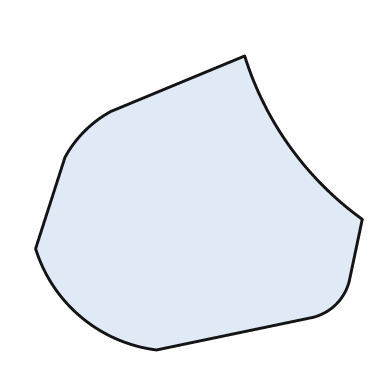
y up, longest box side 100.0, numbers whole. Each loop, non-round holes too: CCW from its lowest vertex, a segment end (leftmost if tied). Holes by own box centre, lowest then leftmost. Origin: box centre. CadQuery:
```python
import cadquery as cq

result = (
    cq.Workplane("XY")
    .moveTo(-13.0, -45.0)
    .lineTo(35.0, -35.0)
    .threePointArc((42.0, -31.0), (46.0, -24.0))
    .lineTo(50.0, -5.0)
    .threePointArc((28.0, 17.0), (14.0, 45.0))
    .lineTo(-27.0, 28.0)
    .threePointArc((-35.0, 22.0), (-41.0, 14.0))
    .lineTo(-50.0, -14.0)
    .threePointArc((-36.0, -35.0), (-13.0, -45.0))
    .close()
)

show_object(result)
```